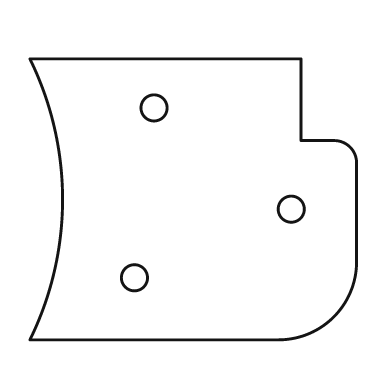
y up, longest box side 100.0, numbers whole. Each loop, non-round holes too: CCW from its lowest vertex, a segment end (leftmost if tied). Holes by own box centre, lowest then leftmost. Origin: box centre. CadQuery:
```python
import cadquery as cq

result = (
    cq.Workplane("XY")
    .moveTo(-50.0, -43.0)
    .lineTo(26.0, -43.0)
    .threePointArc((43.0, -36.0), (50.0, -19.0))
    .lineTo(50.0, 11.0)
    .threePointArc((48.0, 16.0), (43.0, 18.0))
    .lineTo(33.0, 18.0)
    .lineTo(33.0, 43.0)
    .lineTo(-50.0, 43.0)
    .threePointArc((-40.0, 0.0), (-50.0, -43.0))
    .close()
    .moveTo(-18.0, -24.0)
    .circle(4.0)
    .moveTo(30.0, -3.0)
    .circle(4.0)
    .moveTo(-12.0, 28.0)
    .circle(4.0)
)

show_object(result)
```